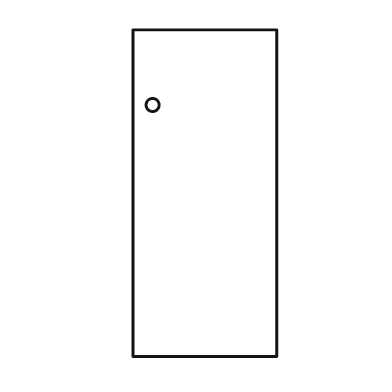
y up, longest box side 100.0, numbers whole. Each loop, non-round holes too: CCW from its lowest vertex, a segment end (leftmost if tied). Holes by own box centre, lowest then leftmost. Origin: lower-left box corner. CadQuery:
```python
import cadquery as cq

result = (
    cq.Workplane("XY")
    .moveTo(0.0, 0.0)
    .lineTo(44.0, 0.0)
    .lineTo(44.0, 100.0)
    .lineTo(0.0, 100.0)
    .close()
    .moveTo(6.0, 77.0)
    .circle(2.0)
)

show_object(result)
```